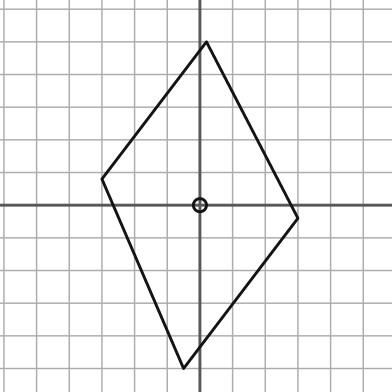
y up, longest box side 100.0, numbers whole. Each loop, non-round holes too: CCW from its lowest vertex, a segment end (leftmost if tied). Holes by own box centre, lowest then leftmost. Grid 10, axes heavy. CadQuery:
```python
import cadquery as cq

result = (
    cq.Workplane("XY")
    .moveTo(-5.0, -50.0)
    .lineTo(30.0, -4.0)
    .lineTo(2.0, 50.0)
    .lineTo(-30.0, 8.0)
    .close()
    .moveTo(0.0, 0.0)
    .circle(2.0)
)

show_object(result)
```